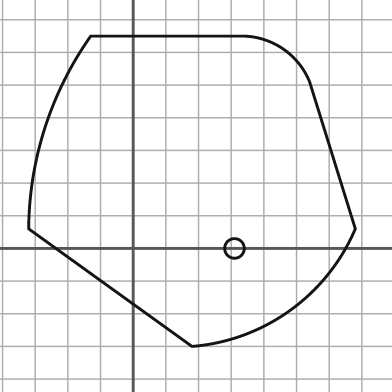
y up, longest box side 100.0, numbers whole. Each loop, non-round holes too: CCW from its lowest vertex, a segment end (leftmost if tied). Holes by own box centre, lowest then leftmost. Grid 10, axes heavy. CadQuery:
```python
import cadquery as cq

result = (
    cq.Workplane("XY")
    .moveTo(18.0, -30.0)
    .threePointArc((48.0, -19.0), (68.0, 6.0))
    .lineTo(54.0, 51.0)
    .threePointArc((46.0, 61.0), (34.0, 65.0))
    .lineTo(-13.0, 65.0)
    .threePointArc((-27.0, 37.0), (-32.0, 6.0))
    .close()
    .moveTo(31.0, 0.0)
    .circle(3.0)
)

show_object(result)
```